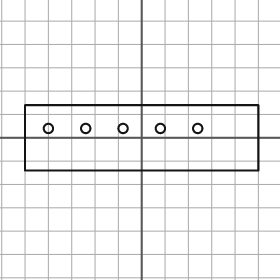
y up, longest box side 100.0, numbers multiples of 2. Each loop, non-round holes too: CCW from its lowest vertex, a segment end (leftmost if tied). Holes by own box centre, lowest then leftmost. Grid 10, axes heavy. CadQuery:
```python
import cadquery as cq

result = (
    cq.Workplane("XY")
    .moveTo(-50.0, -14.0)
    .lineTo(50.0, -14.0)
    .lineTo(50.0, 14.0)
    .lineTo(-50.0, 14.0)
    .close()
    .moveTo(-40.0, 4.0)
    .circle(2.0)
    .moveTo(-24.0, 4.0)
    .circle(2.0)
    .moveTo(-8.0, 4.0)
    .circle(2.0)
    .moveTo(8.0, 4.0)
    .circle(2.0)
    .moveTo(24.0, 4.0)
    .circle(2.0)
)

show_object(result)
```